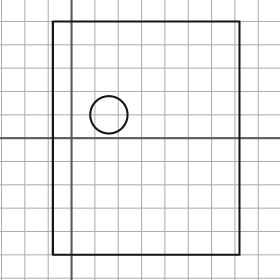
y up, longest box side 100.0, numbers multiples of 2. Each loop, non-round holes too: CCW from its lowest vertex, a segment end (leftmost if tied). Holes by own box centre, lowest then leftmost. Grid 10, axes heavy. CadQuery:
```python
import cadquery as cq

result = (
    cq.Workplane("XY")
    .moveTo(-8.0, -50.0)
    .lineTo(72.0, -50.0)
    .lineTo(72.0, 50.0)
    .lineTo(-8.0, 50.0)
    .close()
    .moveTo(16.0, 10.0)
    .circle(8.0)
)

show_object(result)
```